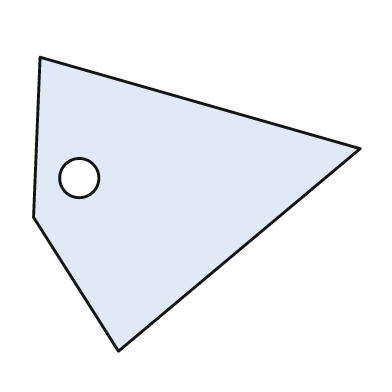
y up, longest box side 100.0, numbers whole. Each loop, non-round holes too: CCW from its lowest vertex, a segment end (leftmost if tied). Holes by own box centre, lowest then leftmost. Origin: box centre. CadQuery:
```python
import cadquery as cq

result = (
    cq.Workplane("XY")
    .moveTo(-24.0, -45.0)
    .lineTo(50.0, 17.0)
    .lineTo(-48.0, 45.0)
    .lineTo(-50.0, -4.0)
    .close()
    .moveTo(-36.0, 8.0)
    .circle(6.0)
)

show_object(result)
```